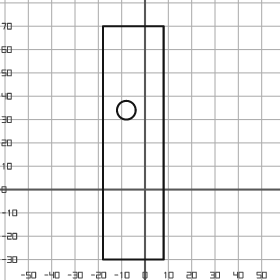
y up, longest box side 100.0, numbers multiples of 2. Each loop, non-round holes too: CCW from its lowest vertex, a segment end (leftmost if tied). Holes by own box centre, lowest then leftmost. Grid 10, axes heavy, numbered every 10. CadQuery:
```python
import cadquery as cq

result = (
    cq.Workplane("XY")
    .moveTo(-18.0, -30.0)
    .lineTo(8.0, -30.0)
    .lineTo(8.0, 70.0)
    .lineTo(-18.0, 70.0)
    .close()
    .moveTo(-8.0, 34.0)
    .circle(4.0)
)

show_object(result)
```